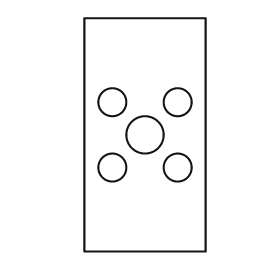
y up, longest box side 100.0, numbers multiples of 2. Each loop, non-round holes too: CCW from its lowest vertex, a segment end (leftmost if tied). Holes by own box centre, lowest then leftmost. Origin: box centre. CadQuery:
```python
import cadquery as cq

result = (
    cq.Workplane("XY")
    .moveTo(-26.0, -50.0)
    .lineTo(26.0, -50.0)
    .lineTo(26.0, 50.0)
    .lineTo(-26.0, 50.0)
    .close()
    .moveTo(-14.0, -14.0)
    .circle(6.0)
    .moveTo(14.0, -14.0)
    .circle(6.0)
    .moveTo(0.0, 0.0)
    .circle(8.0)
    .moveTo(-14.0, 14.0)
    .circle(6.0)
    .moveTo(14.0, 14.0)
    .circle(6.0)
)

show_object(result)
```